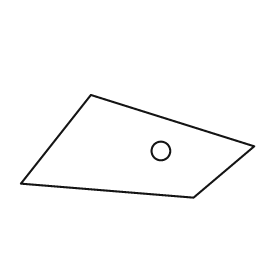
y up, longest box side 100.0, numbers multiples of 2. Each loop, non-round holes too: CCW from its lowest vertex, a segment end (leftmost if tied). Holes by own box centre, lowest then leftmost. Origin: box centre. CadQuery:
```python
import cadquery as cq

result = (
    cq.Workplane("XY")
    .moveTo(24.0, -22.0)
    .lineTo(50.0, 0.0)
    .lineTo(-20.0, 22.0)
    .lineTo(-50.0, -16.0)
    .close()
    .moveTo(10.0, -2.0)
    .circle(4.0)
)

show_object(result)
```